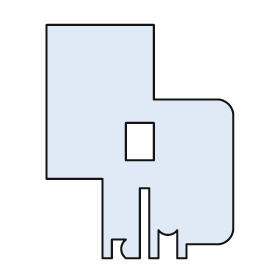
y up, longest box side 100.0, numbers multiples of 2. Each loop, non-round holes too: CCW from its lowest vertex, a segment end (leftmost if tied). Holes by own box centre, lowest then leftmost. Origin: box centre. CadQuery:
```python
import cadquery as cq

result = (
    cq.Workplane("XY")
    .moveTo(-16.0, -50.0)
    .lineTo(-12.0, -50.0)
    .lineTo(-12.0, -42.0)
    .lineTo(-6.0, -42.0)
    .threePointArc((-8.0, -46.0), (-6.0, -50.0))
    .lineTo(0.0, -50.0)
    .lineTo(0.0, -20.0)
    .lineTo(4.0, -20.0)
    .lineTo(4.0, -50.0)
    .lineTo(8.0, -50.0)
    .lineTo(8.0, -38.0)
    .threePointArc((12.0, -40.0), (16.0, -38.0))
    .lineTo(16.0, -50.0)
    .lineTo(20.0, -50.0)
    .lineTo(20.0, -44.0)
    .lineTo(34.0, -44.0)
    .threePointArc((38.0, -42.0), (40.0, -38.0))
    .lineTo(40.0, 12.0)
    .threePointArc((38.0, 16.0), (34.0, 18.0))
    .lineTo(6.0, 18.0)
    .lineTo(6.0, 50.0)
    .lineTo(-40.0, 50.0)
    .lineTo(-40.0, -16.0)
    .lineTo(-16.0, -16.0)
    .close()
    .moveTo(-6.0, -8.0)
    .lineTo(6.0, -8.0)
    .lineTo(6.0, 8.0)
    .lineTo(-6.0, 8.0)
    .close()
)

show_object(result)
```